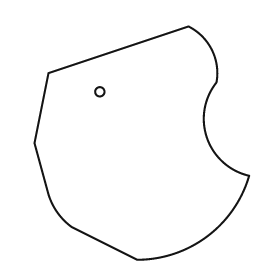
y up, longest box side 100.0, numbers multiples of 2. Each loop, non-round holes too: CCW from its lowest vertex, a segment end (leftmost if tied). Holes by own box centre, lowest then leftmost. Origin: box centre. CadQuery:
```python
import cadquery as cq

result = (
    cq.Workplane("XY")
    .moveTo(-2.0, -50.0)
    .threePointArc((28.0, -40.0), (46.0, -14.0))
    .threePointArc((28.0, 2.0), (32.0, 26.0))
    .threePointArc((30.0, 40.0), (20.0, 50.0))
    .lineTo(-40.0, 30.0)
    .lineTo(-46.0, 0.0)
    .lineTo(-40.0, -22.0)
    .threePointArc((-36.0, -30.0), (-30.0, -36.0))
    .close()
    .moveTo(-18.0, 22.0)
    .circle(2.0)
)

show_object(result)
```